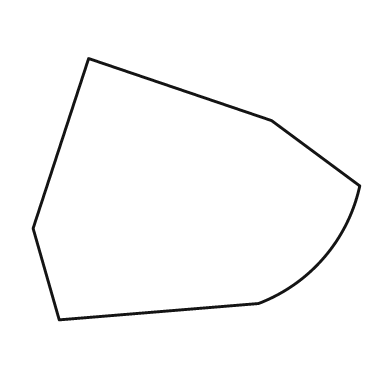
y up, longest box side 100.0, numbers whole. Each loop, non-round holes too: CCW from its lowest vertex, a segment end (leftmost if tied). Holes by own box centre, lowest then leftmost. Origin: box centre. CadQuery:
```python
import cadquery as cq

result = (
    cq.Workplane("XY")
    .moveTo(-42.0, -40.0)
    .lineTo(19.0, -35.0)
    .threePointArc((39.0, -21.0), (50.0, 1.0))
    .lineTo(23.0, 21.0)
    .lineTo(-33.0, 40.0)
    .lineTo(-50.0, -12.0)
    .close()
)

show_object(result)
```